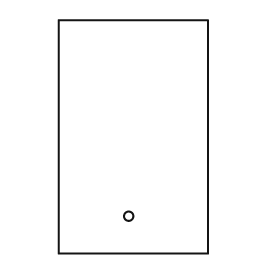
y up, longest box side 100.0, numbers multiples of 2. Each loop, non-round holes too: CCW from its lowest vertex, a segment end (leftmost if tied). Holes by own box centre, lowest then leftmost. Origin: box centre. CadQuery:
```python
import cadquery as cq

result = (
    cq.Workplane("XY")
    .moveTo(-32.0, -50.0)
    .lineTo(32.0, -50.0)
    .lineTo(32.0, 50.0)
    .lineTo(-32.0, 50.0)
    .close()
    .moveTo(-2.0, -34.0)
    .circle(2.0)
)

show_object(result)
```